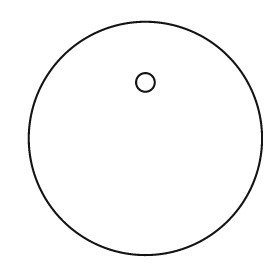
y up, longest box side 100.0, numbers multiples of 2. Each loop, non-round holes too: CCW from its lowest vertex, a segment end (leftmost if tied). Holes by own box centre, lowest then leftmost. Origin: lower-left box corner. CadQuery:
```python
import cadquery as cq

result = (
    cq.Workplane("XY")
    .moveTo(50.0, 50.0)
    .circle(50.0)
    .moveTo(50.0, 74.0)
    .circle(4.0)
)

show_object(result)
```